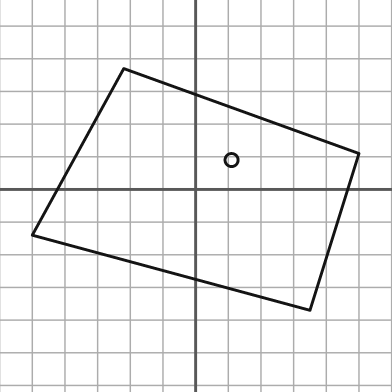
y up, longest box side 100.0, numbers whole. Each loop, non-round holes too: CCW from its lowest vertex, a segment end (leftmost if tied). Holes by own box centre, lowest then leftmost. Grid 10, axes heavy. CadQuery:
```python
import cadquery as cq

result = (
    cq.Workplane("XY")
    .moveTo(35.0, -37.0)
    .lineTo(50.0, 11.0)
    .lineTo(-22.0, 37.0)
    .lineTo(-50.0, -14.0)
    .close()
    .moveTo(11.0, 9.0)
    .circle(2.0)
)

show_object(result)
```